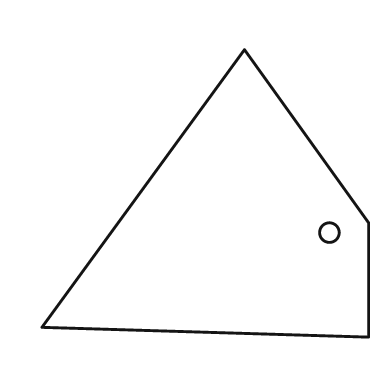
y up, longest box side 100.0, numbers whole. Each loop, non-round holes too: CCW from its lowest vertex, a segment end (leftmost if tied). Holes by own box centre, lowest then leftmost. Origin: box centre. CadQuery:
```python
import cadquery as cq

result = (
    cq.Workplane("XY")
    .moveTo(50.0, -44.0)
    .lineTo(50.0, -9.0)
    .lineTo(12.0, 44.0)
    .lineTo(-50.0, -41.0)
    .close()
    .moveTo(38.0, -12.0)
    .circle(3.0)
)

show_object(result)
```